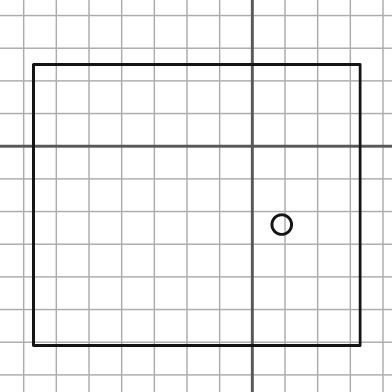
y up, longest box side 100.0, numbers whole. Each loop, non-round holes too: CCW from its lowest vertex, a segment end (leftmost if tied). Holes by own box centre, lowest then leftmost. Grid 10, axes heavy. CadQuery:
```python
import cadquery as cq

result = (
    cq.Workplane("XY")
    .moveTo(-67.0, -61.0)
    .lineTo(33.0, -61.0)
    .lineTo(33.0, 25.0)
    .lineTo(-67.0, 25.0)
    .close()
    .moveTo(9.0, -24.0)
    .circle(3.0)
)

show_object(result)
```